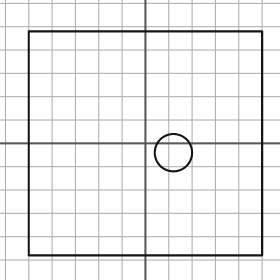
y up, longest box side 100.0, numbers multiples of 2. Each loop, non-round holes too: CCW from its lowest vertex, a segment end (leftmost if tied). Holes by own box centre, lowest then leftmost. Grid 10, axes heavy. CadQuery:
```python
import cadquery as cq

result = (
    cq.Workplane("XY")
    .moveTo(-50.0, -48.0)
    .lineTo(50.0, -48.0)
    .lineTo(50.0, 48.0)
    .lineTo(-50.0, 48.0)
    .close()
    .moveTo(12.0, -4.0)
    .circle(8.0)
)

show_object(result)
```